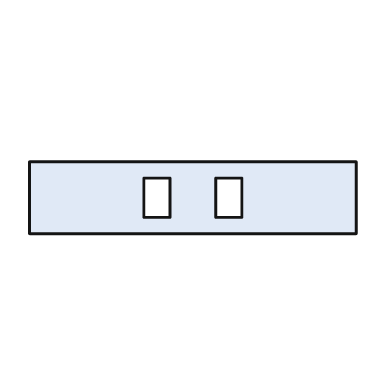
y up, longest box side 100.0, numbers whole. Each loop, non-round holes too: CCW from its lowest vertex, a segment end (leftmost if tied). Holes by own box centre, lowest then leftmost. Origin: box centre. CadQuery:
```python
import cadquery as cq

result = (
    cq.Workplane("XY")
    .moveTo(-50.0, -11.0)
    .lineTo(50.0, -11.0)
    .lineTo(50.0, 11.0)
    .lineTo(-50.0, 11.0)
    .close()
    .moveTo(-15.0, -6.0)
    .lineTo(-7.0, -6.0)
    .lineTo(-7.0, 6.0)
    .lineTo(-15.0, 6.0)
    .close()
    .moveTo(7.0, -6.0)
    .lineTo(15.0, -6.0)
    .lineTo(15.0, 6.0)
    .lineTo(7.0, 6.0)
    .close()
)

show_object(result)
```